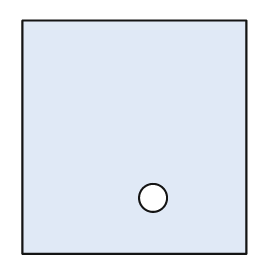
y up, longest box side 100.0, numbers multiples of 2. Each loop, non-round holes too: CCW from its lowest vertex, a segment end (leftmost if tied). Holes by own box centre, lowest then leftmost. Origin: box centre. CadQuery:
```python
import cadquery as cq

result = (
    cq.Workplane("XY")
    .moveTo(-48.0, -50.0)
    .lineTo(48.0, -50.0)
    .lineTo(48.0, 50.0)
    .lineTo(-48.0, 50.0)
    .close()
    .moveTo(8.0, -26.0)
    .circle(6.0)
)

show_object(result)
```